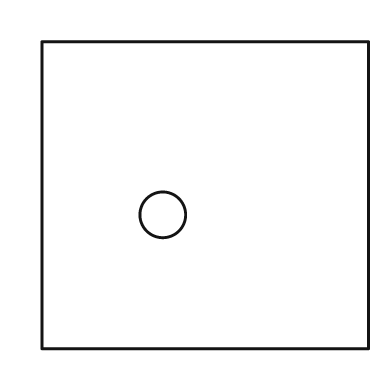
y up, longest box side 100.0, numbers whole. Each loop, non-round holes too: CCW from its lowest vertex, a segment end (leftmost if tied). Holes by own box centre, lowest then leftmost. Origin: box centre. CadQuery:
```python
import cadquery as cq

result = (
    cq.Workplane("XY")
    .moveTo(-50.0, -47.0)
    .lineTo(50.0, -47.0)
    .lineTo(50.0, 47.0)
    .lineTo(-50.0, 47.0)
    .close()
    .moveTo(-13.0, -6.0)
    .circle(7.0)
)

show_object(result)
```